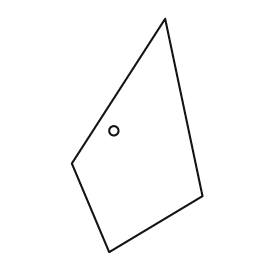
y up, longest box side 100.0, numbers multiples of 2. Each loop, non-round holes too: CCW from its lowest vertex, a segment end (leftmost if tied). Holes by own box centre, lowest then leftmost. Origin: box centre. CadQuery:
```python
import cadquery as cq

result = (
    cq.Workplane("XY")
    .moveTo(-12.0, -50.0)
    .lineTo(28.0, -26.0)
    .lineTo(12.0, 50.0)
    .lineTo(-28.0, -12.0)
    .close()
    .moveTo(-10.0, 2.0)
    .circle(2.0)
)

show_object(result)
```